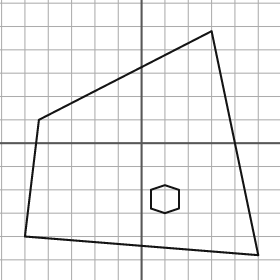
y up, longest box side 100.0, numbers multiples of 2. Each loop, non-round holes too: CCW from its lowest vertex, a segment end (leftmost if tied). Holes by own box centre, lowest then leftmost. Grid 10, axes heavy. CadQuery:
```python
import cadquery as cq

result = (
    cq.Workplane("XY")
    .moveTo(50.0, -48.0)
    .lineTo(30.0, 48.0)
    .lineTo(-44.0, 10.0)
    .lineTo(-50.0, -40.0)
    .close()
    .moveTo(10.0, -30.0)
    .lineTo(16.0, -28.0)
    .lineTo(16.0, -20.0)
    .lineTo(10.0, -18.0)
    .lineTo(4.0, -20.0)
    .lineTo(4.0, -28.0)
    .close()
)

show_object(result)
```